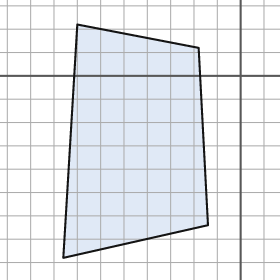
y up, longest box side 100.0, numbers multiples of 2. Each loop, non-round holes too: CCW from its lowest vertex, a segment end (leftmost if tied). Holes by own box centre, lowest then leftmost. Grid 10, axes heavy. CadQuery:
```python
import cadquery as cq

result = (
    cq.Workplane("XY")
    .moveTo(-76.0, -78.0)
    .lineTo(-14.0, -64.0)
    .lineTo(-18.0, 12.0)
    .lineTo(-70.0, 22.0)
    .close()
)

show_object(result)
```